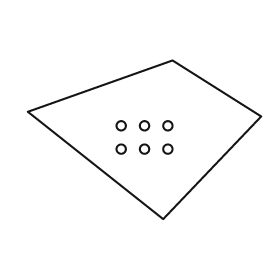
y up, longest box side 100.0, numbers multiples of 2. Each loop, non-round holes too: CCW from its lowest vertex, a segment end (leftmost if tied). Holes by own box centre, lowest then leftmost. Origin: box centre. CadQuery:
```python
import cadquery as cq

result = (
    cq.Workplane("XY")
    .moveTo(8.0, -34.0)
    .lineTo(50.0, 10.0)
    .lineTo(12.0, 34.0)
    .lineTo(-50.0, 12.0)
    .close()
    .moveTo(-10.0, -4.0)
    .circle(2.0)
    .moveTo(0.0, -4.0)
    .circle(2.0)
    .moveTo(10.0, -4.0)
    .circle(2.0)
    .moveTo(-10.0, 6.0)
    .circle(2.0)
    .moveTo(0.0, 6.0)
    .circle(2.0)
    .moveTo(10.0, 6.0)
    .circle(2.0)
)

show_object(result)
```